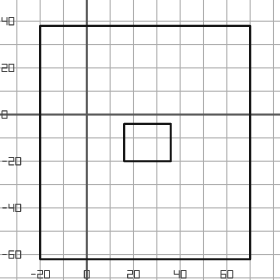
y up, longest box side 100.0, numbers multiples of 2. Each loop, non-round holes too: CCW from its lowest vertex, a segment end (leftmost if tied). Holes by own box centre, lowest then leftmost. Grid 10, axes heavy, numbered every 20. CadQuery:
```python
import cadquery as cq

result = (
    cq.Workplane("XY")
    .moveTo(-20.0, -62.0)
    .lineTo(70.0, -62.0)
    .lineTo(70.0, 38.0)
    .lineTo(-20.0, 38.0)
    .close()
    .moveTo(16.0, -20.0)
    .lineTo(36.0, -20.0)
    .lineTo(36.0, -4.0)
    .lineTo(16.0, -4.0)
    .close()
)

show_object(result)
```